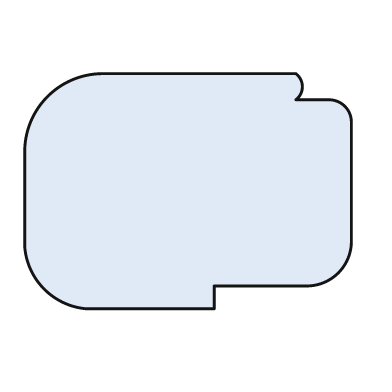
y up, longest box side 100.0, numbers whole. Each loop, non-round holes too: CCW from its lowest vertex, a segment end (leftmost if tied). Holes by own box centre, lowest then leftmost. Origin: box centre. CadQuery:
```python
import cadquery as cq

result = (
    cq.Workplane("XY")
    .moveTo(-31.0, -36.0)
    .lineTo(8.0, -36.0)
    .lineTo(8.0, -29.0)
    .lineTo(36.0, -29.0)
    .threePointArc((46.0, -25.0), (50.0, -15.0))
    .lineTo(50.0, 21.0)
    .threePointArc((48.0, 26.0), (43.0, 28.0))
    .lineTo(33.0, 28.0)
    .threePointArc((35.0, 32.0), (33.0, 36.0))
    .lineTo(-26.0, 36.0)
    .threePointArc((-43.0, 29.0), (-50.0, 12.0))
    .lineTo(-50.0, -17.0)
    .threePointArc((-44.0, -30.0), (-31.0, -36.0))
    .close()
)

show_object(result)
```